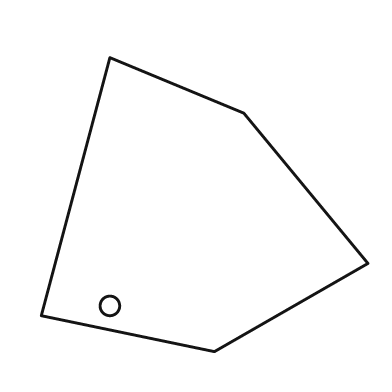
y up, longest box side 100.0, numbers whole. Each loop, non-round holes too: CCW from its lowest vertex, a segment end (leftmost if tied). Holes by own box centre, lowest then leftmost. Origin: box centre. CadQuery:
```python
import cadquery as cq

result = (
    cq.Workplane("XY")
    .moveTo(3.0, -45.0)
    .lineTo(50.0, -18.0)
    .lineTo(12.0, 28.0)
    .lineTo(-29.0, 45.0)
    .lineTo(-50.0, -34.0)
    .close()
    .moveTo(-29.0, -31.0)
    .circle(3.0)
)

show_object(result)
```